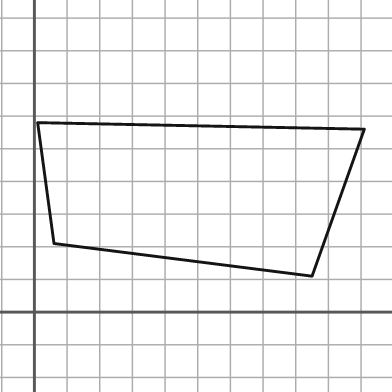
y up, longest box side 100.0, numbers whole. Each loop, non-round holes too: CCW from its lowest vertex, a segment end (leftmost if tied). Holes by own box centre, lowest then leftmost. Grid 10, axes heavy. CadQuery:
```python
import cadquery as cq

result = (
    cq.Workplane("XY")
    .moveTo(85.0, 11.0)
    .lineTo(101.0, 56.0)
    .lineTo(1.0, 58.0)
    .lineTo(6.0, 21.0)
    .close()
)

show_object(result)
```